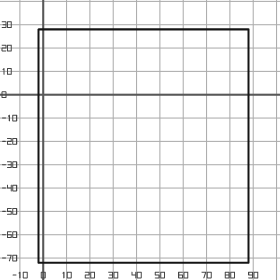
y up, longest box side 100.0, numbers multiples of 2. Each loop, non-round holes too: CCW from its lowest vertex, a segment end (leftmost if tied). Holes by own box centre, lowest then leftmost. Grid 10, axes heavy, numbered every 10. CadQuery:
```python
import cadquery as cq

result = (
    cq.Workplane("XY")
    .moveTo(-2.0, -72.0)
    .lineTo(88.0, -72.0)
    .lineTo(88.0, 28.0)
    .lineTo(-2.0, 28.0)
    .close()
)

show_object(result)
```